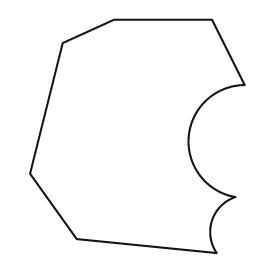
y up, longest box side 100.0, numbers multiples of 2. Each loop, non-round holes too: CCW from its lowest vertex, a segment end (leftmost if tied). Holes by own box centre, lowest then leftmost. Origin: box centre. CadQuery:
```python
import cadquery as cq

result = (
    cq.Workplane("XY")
    .moveTo(34.0, -50.0)
    .threePointArc((32.0, -36.0), (42.0, -26.0))
    .threePointArc((22.0, 0.0), (46.0, 22.0))
    .lineTo(32.0, 50.0)
    .lineTo(-10.0, 50.0)
    .lineTo(-32.0, 40.0)
    .lineTo(-46.0, -16.0)
    .lineTo(-26.0, -44.0)
    .close()
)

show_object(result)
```